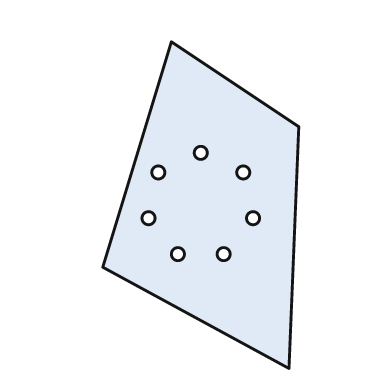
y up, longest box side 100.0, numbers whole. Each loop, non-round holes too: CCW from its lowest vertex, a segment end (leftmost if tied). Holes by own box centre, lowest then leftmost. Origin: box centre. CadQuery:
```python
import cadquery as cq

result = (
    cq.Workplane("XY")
    .moveTo(27.0, -50.0)
    .lineTo(30.0, 24.0)
    .lineTo(-9.0, 50.0)
    .lineTo(-30.0, -19.0)
    .close()
    .moveTo(-7.0, -15.0)
    .circle(2.0)
    .moveTo(7.0, -15.0)
    .circle(2.0)
    .moveTo(-16.0, -4.0)
    .circle(2.0)
    .moveTo(16.0, -4.0)
    .circle(2.0)
    .moveTo(-13.0, 10.0)
    .circle(2.0)
    .moveTo(13.0, 10.0)
    .circle(2.0)
    .moveTo(0.0, 16.0)
    .circle(2.0)
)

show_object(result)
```